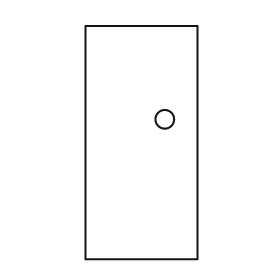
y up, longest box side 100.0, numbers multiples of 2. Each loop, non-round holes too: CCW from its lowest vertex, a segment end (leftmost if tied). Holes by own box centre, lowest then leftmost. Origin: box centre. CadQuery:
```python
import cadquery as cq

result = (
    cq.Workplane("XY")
    .moveTo(-24.0, -50.0)
    .lineTo(24.0, -50.0)
    .lineTo(24.0, 50.0)
    .lineTo(-24.0, 50.0)
    .close()
    .moveTo(10.0, 10.0)
    .circle(4.0)
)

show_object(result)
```